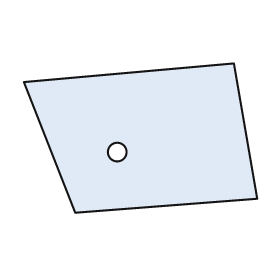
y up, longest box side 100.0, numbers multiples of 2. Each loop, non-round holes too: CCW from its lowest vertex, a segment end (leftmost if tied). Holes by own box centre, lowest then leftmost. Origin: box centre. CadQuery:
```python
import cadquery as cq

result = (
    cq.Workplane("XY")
    .moveTo(-28.0, -32.0)
    .lineTo(50.0, -26.0)
    .lineTo(40.0, 32.0)
    .lineTo(-50.0, 24.0)
    .close()
    .moveTo(-10.0, -6.0)
    .circle(4.0)
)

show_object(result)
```